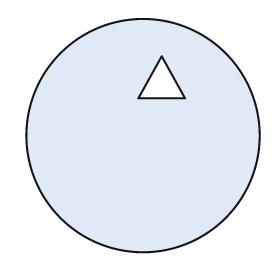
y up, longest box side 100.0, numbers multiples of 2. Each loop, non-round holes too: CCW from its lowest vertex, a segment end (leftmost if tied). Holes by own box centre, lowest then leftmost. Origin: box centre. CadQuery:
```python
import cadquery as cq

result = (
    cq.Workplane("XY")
    .moveTo(0.0, 0.0)
    .circle(50.0)
    .moveTo(-2.0, 16.0)
    .lineTo(18.0, 16.0)
    .lineTo(8.0, 34.0)
    .close()
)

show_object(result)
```